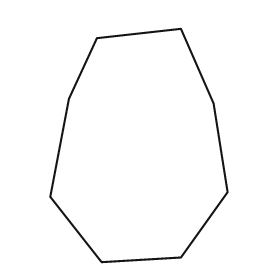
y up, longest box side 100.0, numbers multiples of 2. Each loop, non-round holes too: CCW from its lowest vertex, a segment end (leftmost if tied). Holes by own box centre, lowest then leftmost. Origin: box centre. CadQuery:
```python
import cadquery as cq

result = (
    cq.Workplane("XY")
    .moveTo(-16.0, -50.0)
    .lineTo(18.0, -48.0)
    .lineTo(38.0, -20.0)
    .lineTo(32.0, 18.0)
    .lineTo(18.0, 50.0)
    .lineTo(-18.0, 46.0)
    .lineTo(-30.0, 20.0)
    .lineTo(-38.0, -22.0)
    .close()
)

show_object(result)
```